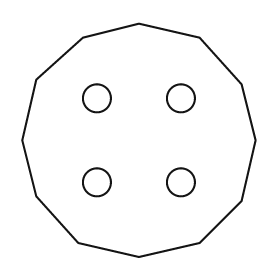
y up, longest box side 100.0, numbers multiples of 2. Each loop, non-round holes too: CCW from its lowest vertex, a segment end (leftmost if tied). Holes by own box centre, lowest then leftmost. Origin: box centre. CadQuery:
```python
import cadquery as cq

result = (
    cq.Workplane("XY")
    .moveTo(0.0, -50.0)
    .lineTo(26.0, -44.0)
    .lineTo(44.0, -26.0)
    .lineTo(50.0, 0.0)
    .lineTo(44.0, 24.0)
    .lineTo(26.0, 44.0)
    .lineTo(0.0, 50.0)
    .lineTo(-24.0, 44.0)
    .lineTo(-44.0, 26.0)
    .lineTo(-50.0, 0.0)
    .lineTo(-44.0, -24.0)
    .lineTo(-26.0, -44.0)
    .close()
    .moveTo(-18.0, -18.0)
    .circle(6.0)
    .moveTo(18.0, -18.0)
    .circle(6.0)
    .moveTo(-18.0, 18.0)
    .circle(6.0)
    .moveTo(18.0, 18.0)
    .circle(6.0)
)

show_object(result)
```